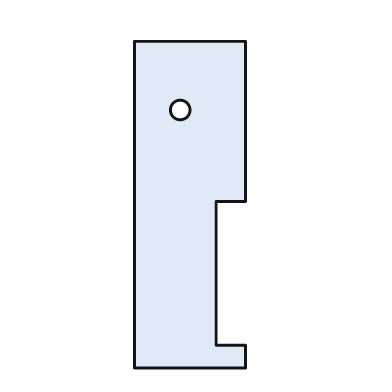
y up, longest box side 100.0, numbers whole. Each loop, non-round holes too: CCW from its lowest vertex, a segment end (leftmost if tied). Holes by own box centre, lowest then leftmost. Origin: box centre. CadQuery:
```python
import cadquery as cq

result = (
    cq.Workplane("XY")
    .moveTo(-17.0, -50.0)
    .lineTo(17.0, -50.0)
    .lineTo(17.0, -43.0)
    .lineTo(8.0, -43.0)
    .lineTo(8.0, 1.0)
    .lineTo(17.0, 1.0)
    .lineTo(17.0, 50.0)
    .lineTo(-17.0, 50.0)
    .close()
    .moveTo(-3.0, 29.0)
    .circle(3.0)
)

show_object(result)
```